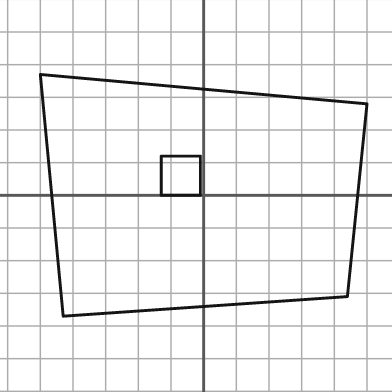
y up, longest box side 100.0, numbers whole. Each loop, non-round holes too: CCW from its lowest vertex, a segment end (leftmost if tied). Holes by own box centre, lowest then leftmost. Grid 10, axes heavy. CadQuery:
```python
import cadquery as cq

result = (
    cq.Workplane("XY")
    .moveTo(-43.0, -37.0)
    .lineTo(44.0, -31.0)
    .lineTo(50.0, 28.0)
    .lineTo(-50.0, 37.0)
    .close()
    .moveTo(-13.0, 0.0)
    .lineTo(-1.0, 0.0)
    .lineTo(-1.0, 12.0)
    .lineTo(-13.0, 12.0)
    .close()
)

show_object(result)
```